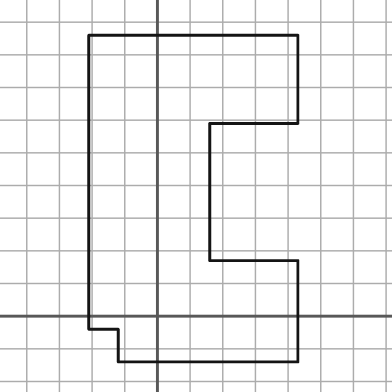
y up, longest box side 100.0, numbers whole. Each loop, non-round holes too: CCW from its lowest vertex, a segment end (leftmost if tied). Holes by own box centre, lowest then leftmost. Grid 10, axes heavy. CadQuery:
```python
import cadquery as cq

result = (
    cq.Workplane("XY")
    .moveTo(-12.0, -14.0)
    .lineTo(43.0, -14.0)
    .lineTo(43.0, 17.0)
    .lineTo(16.0, 17.0)
    .lineTo(16.0, 59.0)
    .lineTo(43.0, 59.0)
    .lineTo(43.0, 86.0)
    .lineTo(-21.0, 86.0)
    .lineTo(-21.0, -4.0)
    .lineTo(-12.0, -4.0)
    .close()
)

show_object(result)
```